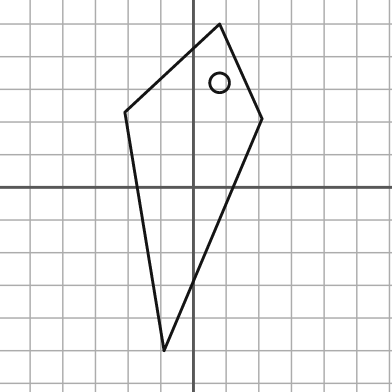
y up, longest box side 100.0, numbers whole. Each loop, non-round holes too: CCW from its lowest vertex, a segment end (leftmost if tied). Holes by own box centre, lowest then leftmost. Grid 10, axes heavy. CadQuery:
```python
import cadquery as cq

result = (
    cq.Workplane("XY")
    .moveTo(-9.0, -50.0)
    .lineTo(21.0, 21.0)
    .lineTo(8.0, 50.0)
    .lineTo(-21.0, 23.0)
    .close()
    .moveTo(8.0, 32.0)
    .circle(3.0)
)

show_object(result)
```